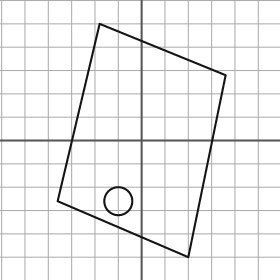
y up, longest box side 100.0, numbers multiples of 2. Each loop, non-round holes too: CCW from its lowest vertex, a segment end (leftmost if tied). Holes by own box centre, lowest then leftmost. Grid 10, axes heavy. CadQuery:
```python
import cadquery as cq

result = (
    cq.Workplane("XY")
    .moveTo(20.0, -50.0)
    .lineTo(36.0, 28.0)
    .lineTo(-18.0, 50.0)
    .lineTo(-36.0, -26.0)
    .close()
    .moveTo(-10.0, -26.0)
    .circle(6.0)
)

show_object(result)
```